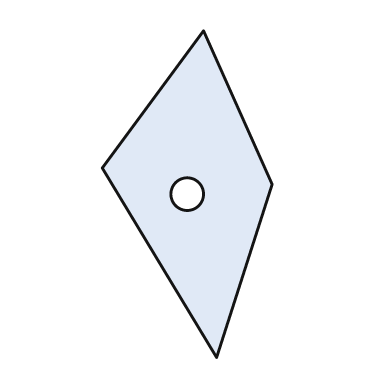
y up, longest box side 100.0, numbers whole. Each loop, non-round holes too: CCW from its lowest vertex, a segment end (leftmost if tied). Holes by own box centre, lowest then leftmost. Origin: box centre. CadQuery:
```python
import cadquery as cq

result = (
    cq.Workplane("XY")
    .moveTo(9.0, -50.0)
    .lineTo(26.0, 3.0)
    .lineTo(5.0, 50.0)
    .lineTo(-26.0, 8.0)
    .close()
    .moveTo(0.0, 0.0)
    .circle(5.0)
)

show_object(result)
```